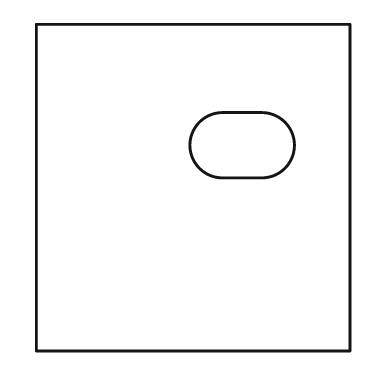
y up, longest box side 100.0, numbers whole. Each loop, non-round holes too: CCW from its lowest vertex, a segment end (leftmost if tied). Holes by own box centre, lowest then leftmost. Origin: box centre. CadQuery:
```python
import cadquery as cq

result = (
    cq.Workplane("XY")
    .moveTo(-48.0, -50.0)
    .lineTo(48.0, -50.0)
    .lineTo(48.0, 50.0)
    .lineTo(-48.0, 50.0)
    .close()
    .moveTo(9.0, 3.0)
    .lineTo(21.0, 3.0)
    .threePointArc((31.0, 13.0), (21.0, 23.0))
    .lineTo(9.0, 23.0)
    .threePointArc((-1.0, 13.0), (9.0, 3.0))
    .close()
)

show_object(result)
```